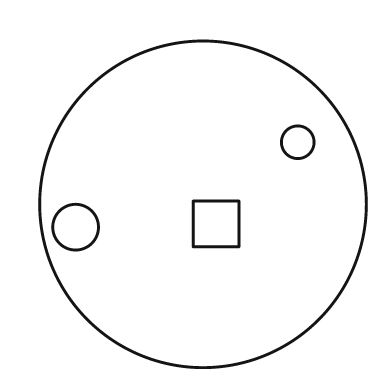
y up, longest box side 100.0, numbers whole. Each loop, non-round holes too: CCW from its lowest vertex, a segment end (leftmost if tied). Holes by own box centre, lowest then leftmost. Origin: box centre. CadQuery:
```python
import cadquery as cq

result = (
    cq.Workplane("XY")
    .moveTo(0.0, 0.0)
    .circle(50.0)
    .moveTo(-39.0, -7.0)
    .circle(7.0)
    .moveTo(-3.0, -13.0)
    .lineTo(11.0, -13.0)
    .lineTo(11.0, 1.0)
    .lineTo(-3.0, 1.0)
    .close()
    .moveTo(29.0, 19.0)
    .circle(5.0)
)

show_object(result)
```